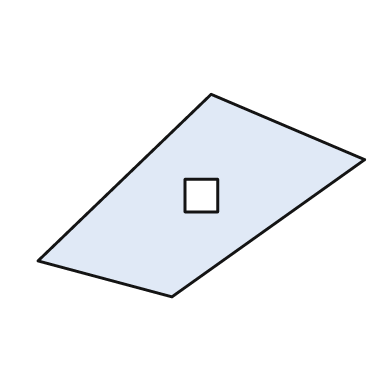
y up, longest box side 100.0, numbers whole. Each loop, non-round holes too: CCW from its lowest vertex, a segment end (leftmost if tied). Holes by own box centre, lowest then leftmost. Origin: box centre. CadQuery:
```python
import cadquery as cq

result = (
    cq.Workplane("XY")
    .moveTo(-9.0, -31.0)
    .lineTo(50.0, 11.0)
    .lineTo(3.0, 31.0)
    .lineTo(-50.0, -20.0)
    .close()
    .moveTo(-5.0, -5.0)
    .lineTo(5.0, -5.0)
    .lineTo(5.0, 5.0)
    .lineTo(-5.0, 5.0)
    .close()
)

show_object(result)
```